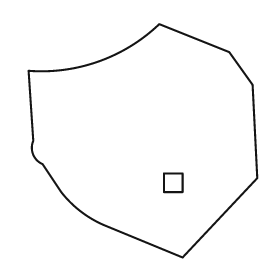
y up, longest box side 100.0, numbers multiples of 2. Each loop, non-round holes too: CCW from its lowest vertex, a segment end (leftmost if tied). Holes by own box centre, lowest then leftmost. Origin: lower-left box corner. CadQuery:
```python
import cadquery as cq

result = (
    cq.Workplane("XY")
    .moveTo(66.0, 0.0)
    .lineTo(98.0, 34.0)
    .lineTo(96.0, 74.0)
    .lineTo(86.0, 88.0)
    .lineTo(56.0, 100.0)
    .threePointArc((30.0, 84.0), (0.0, 80.0))
    .lineTo(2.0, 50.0)
    .threePointArc((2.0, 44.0), (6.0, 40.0))
    .lineTo(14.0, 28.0)
    .threePointArc((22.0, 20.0), (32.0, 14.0))
    .close()
    .moveTo(58.0, 28.0)
    .lineTo(66.0, 28.0)
    .lineTo(66.0, 36.0)
    .lineTo(58.0, 36.0)
    .close()
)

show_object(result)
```